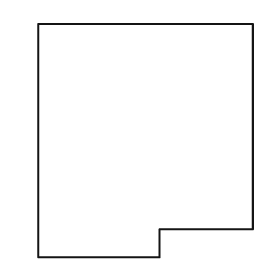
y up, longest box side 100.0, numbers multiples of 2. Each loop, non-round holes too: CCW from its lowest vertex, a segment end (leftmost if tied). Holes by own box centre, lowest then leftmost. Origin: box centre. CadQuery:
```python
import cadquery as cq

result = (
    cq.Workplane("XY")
    .moveTo(-46.0, -50.0)
    .lineTo(6.0, -50.0)
    .lineTo(6.0, -38.0)
    .lineTo(46.0, -38.0)
    .lineTo(46.0, 50.0)
    .lineTo(-46.0, 50.0)
    .close()
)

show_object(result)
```